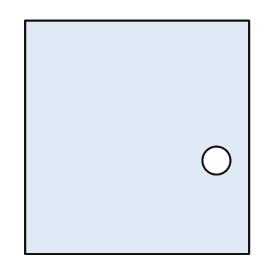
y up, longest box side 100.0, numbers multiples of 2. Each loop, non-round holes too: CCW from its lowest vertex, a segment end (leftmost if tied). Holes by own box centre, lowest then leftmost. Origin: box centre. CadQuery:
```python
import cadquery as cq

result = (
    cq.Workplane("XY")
    .moveTo(-48.0, -50.0)
    .lineTo(48.0, -50.0)
    .lineTo(48.0, 50.0)
    .lineTo(-48.0, 50.0)
    .close()
    .moveTo(34.0, -10.0)
    .circle(6.0)
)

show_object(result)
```